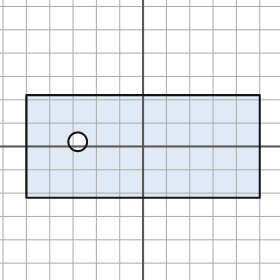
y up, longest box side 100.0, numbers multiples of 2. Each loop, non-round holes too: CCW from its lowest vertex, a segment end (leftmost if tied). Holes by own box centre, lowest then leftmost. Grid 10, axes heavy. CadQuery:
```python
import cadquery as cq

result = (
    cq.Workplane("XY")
    .moveTo(-50.0, -22.0)
    .lineTo(50.0, -22.0)
    .lineTo(50.0, 22.0)
    .lineTo(-50.0, 22.0)
    .close()
    .moveTo(-28.0, 2.0)
    .circle(4.0)
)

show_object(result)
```